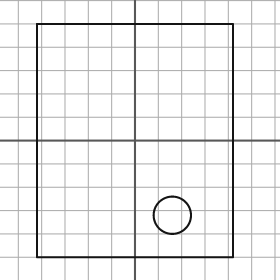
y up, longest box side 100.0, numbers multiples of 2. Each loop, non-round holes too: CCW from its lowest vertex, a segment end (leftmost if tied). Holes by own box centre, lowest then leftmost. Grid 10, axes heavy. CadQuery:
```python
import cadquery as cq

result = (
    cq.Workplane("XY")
    .moveTo(-42.0, -50.0)
    .lineTo(42.0, -50.0)
    .lineTo(42.0, 50.0)
    .lineTo(-42.0, 50.0)
    .close()
    .moveTo(16.0, -32.0)
    .circle(8.0)
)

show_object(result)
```